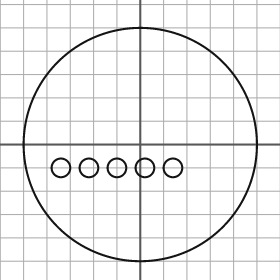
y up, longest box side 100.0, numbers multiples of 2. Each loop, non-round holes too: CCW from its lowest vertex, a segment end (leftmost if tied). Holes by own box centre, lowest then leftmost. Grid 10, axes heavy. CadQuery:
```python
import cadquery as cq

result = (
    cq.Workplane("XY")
    .moveTo(0.0, 0.0)
    .circle(50.0)
    .moveTo(-34.0, -10.0)
    .circle(4.0)
    .moveTo(-22.0, -10.0)
    .circle(4.0)
    .moveTo(-10.0, -10.0)
    .circle(4.0)
    .moveTo(2.0, -10.0)
    .circle(4.0)
    .moveTo(14.0, -10.0)
    .circle(4.0)
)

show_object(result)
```